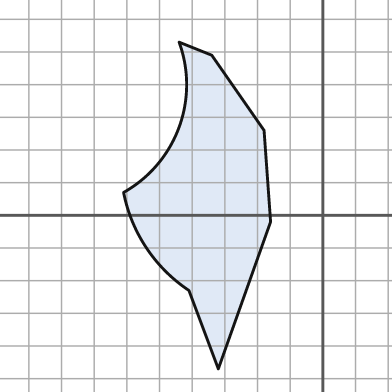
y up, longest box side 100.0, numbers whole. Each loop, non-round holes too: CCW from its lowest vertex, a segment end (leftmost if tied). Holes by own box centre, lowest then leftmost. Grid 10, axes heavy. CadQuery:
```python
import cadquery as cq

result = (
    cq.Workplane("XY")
    .moveTo(-32.0, -47.0)
    .lineTo(-16.0, -2.0)
    .lineTo(-18.0, 26.0)
    .lineTo(-34.0, 49.0)
    .lineTo(-44.0, 53.0)
    .threePointArc((-44.0, 27.0), (-61.0, 7.0))
    .threePointArc((-54.0, -10.0), (-41.0, -23.0))
    .close()
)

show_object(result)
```